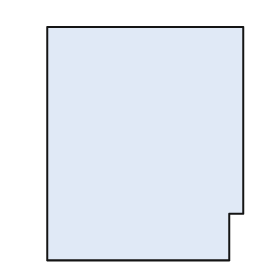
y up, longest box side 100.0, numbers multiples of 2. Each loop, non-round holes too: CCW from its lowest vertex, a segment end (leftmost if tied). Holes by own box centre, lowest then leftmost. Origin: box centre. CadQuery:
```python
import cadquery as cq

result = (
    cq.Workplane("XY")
    .moveTo(-42.0, -50.0)
    .lineTo(36.0, -50.0)
    .lineTo(36.0, -30.0)
    .lineTo(42.0, -30.0)
    .lineTo(42.0, 50.0)
    .lineTo(-42.0, 50.0)
    .close()
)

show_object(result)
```